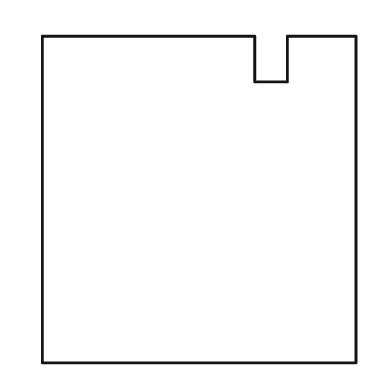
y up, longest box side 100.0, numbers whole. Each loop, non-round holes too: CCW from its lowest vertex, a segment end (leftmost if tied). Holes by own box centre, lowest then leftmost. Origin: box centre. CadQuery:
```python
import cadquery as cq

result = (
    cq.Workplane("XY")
    .moveTo(-48.0, -50.0)
    .lineTo(48.0, -50.0)
    .lineTo(48.0, 50.0)
    .lineTo(27.0, 50.0)
    .lineTo(27.0, 36.0)
    .lineTo(17.0, 36.0)
    .lineTo(17.0, 50.0)
    .lineTo(-48.0, 50.0)
    .close()
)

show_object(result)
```